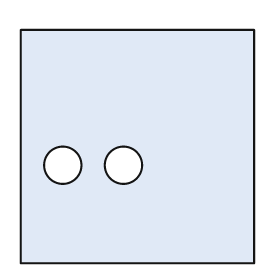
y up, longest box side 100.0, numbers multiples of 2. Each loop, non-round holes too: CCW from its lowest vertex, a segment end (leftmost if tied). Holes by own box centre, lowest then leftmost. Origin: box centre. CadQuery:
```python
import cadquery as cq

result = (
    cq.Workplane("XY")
    .moveTo(-50.0, -50.0)
    .lineTo(50.0, -50.0)
    .lineTo(50.0, 50.0)
    .lineTo(-50.0, 50.0)
    .close()
    .moveTo(-32.0, -8.0)
    .circle(8.0)
    .moveTo(-6.0, -8.0)
    .circle(8.0)
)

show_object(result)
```